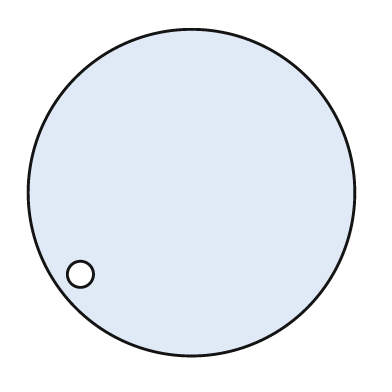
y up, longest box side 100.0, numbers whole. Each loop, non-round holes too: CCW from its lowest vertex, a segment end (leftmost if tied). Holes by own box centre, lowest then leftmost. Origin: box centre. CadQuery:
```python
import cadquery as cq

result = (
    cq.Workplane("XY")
    .moveTo(0.0, 0.0)
    .circle(50.0)
    .moveTo(-34.0, -25.0)
    .circle(4.0)
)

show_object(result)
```